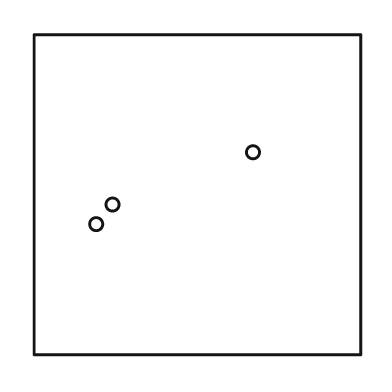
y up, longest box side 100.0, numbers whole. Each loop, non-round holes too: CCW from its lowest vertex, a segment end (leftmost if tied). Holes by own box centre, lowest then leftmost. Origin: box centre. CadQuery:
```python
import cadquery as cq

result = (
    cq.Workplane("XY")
    .moveTo(-50.0, -49.0)
    .lineTo(50.0, -49.0)
    .lineTo(50.0, 49.0)
    .lineTo(-50.0, 49.0)
    .close()
    .moveTo(-31.0, -9.0)
    .circle(2.0)
    .moveTo(-26.0, -3.0)
    .circle(2.0)
    .moveTo(17.0, 13.0)
    .circle(2.0)
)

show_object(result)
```